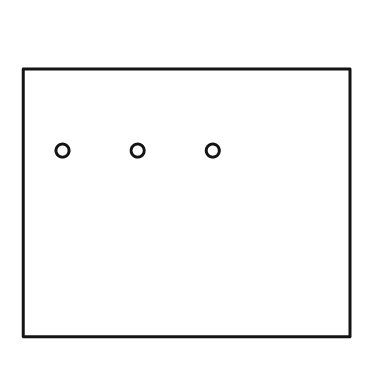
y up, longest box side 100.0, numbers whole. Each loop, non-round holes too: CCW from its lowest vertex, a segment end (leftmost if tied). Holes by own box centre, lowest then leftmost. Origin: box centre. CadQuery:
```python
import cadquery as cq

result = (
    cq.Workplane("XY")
    .moveTo(-50.0, -41.0)
    .lineTo(50.0, -41.0)
    .lineTo(50.0, 41.0)
    .lineTo(-50.0, 41.0)
    .close()
    .moveTo(-38.0, 16.0)
    .circle(2.0)
    .moveTo(-15.0, 16.0)
    .circle(2.0)
    .moveTo(8.0, 16.0)
    .circle(2.0)
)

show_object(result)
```